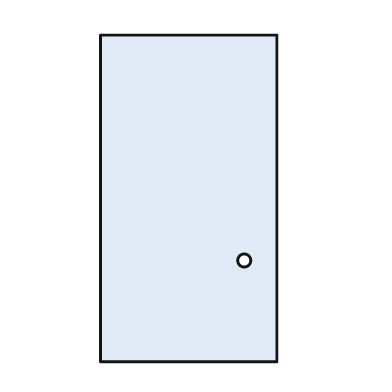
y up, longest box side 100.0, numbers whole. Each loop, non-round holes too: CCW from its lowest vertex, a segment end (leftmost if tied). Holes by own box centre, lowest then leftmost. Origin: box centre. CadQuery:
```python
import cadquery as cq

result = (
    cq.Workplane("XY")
    .moveTo(-27.0, -50.0)
    .lineTo(27.0, -50.0)
    .lineTo(27.0, 50.0)
    .lineTo(-27.0, 50.0)
    .close()
    .moveTo(17.0, -19.0)
    .circle(2.0)
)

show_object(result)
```